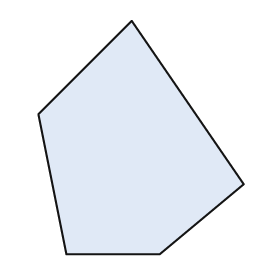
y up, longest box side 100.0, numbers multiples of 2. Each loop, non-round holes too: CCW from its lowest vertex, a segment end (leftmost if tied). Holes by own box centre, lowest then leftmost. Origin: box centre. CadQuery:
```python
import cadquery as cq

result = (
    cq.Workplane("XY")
    .moveTo(-32.0, -50.0)
    .lineTo(8.0, -50.0)
    .lineTo(44.0, -20.0)
    .lineTo(-4.0, 50.0)
    .lineTo(-44.0, 10.0)
    .close()
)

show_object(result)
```